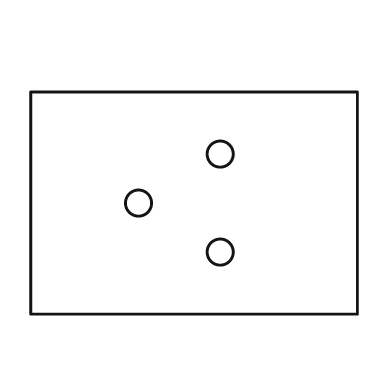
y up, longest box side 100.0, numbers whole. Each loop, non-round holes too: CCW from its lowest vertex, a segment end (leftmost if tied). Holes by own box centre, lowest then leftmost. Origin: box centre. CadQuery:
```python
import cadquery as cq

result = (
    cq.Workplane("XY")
    .moveTo(-50.0, -34.0)
    .lineTo(50.0, -34.0)
    .lineTo(50.0, 34.0)
    .lineTo(-50.0, 34.0)
    .close()
    .moveTo(8.0, -15.0)
    .circle(4.0)
    .moveTo(-17.0, 0.0)
    .circle(4.0)
    .moveTo(8.0, 15.0)
    .circle(4.0)
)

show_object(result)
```